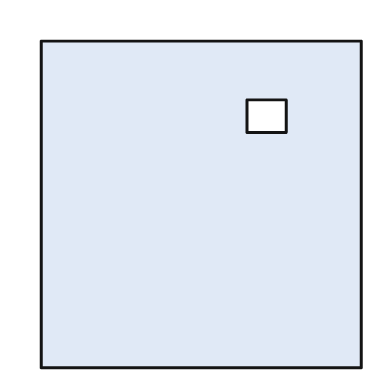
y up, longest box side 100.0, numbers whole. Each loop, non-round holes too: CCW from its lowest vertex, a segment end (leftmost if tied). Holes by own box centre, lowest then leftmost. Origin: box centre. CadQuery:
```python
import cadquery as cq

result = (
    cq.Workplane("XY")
    .moveTo(-49.0, -50.0)
    .lineTo(49.0, -50.0)
    .lineTo(49.0, 50.0)
    .lineTo(-49.0, 50.0)
    .close()
    .moveTo(14.0, 22.0)
    .lineTo(26.0, 22.0)
    .lineTo(26.0, 32.0)
    .lineTo(14.0, 32.0)
    .close()
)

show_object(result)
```